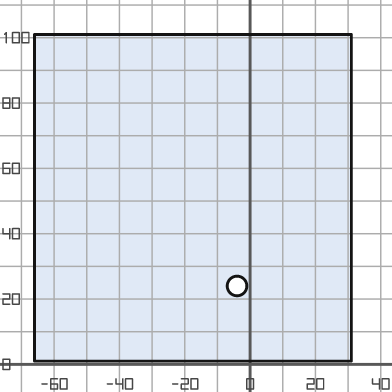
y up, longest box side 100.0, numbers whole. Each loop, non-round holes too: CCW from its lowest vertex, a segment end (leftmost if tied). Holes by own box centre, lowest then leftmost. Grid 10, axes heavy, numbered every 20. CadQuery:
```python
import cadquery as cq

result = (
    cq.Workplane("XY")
    .moveTo(-66.0, 1.0)
    .lineTo(31.0, 1.0)
    .lineTo(31.0, 101.0)
    .lineTo(-66.0, 101.0)
    .close()
    .moveTo(-4.0, 24.0)
    .circle(3.0)
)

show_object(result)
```